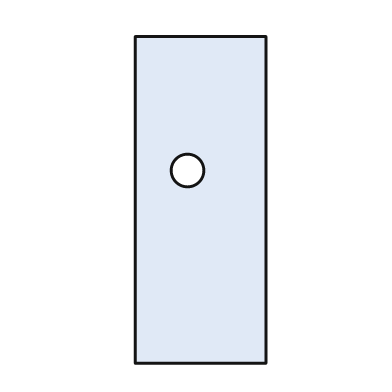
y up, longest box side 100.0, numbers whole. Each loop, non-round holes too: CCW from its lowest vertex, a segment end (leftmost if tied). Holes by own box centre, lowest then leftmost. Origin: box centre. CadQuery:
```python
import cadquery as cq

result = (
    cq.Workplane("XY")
    .moveTo(-20.0, -50.0)
    .lineTo(20.0, -50.0)
    .lineTo(20.0, 50.0)
    .lineTo(-20.0, 50.0)
    .close()
    .moveTo(-4.0, 9.0)
    .circle(5.0)
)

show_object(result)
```